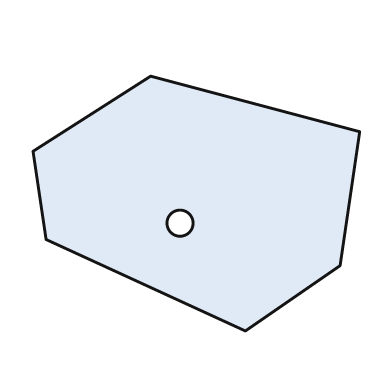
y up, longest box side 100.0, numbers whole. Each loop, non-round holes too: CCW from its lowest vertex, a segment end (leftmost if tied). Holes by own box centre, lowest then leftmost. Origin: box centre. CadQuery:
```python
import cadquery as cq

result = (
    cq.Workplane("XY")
    .moveTo(15.0, -39.0)
    .lineTo(44.0, -19.0)
    .lineTo(50.0, 22.0)
    .lineTo(-14.0, 39.0)
    .lineTo(-50.0, 16.0)
    .lineTo(-46.0, -11.0)
    .close()
    .moveTo(-5.0, -6.0)
    .circle(4.0)
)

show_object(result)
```